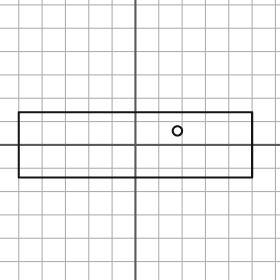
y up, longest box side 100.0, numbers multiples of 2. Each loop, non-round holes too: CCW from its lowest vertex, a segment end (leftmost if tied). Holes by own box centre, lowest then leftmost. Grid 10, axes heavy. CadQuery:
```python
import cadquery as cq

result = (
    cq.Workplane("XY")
    .moveTo(-50.0, -14.0)
    .lineTo(50.0, -14.0)
    .lineTo(50.0, 14.0)
    .lineTo(-50.0, 14.0)
    .close()
    .moveTo(18.0, 6.0)
    .circle(2.0)
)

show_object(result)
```